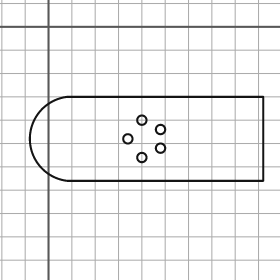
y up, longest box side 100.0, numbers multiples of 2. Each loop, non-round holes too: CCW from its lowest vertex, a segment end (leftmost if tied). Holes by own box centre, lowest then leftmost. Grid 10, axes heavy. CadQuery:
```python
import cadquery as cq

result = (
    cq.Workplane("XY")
    .moveTo(8.0, -66.0)
    .lineTo(92.0, -66.0)
    .lineTo(92.0, -30.0)
    .lineTo(8.0, -30.0)
    .threePointArc((-8.0, -48.0), (8.0, -66.0))
    .close()
    .moveTo(40.0, -56.0)
    .circle(2.0)
    .moveTo(48.0, -52.0)
    .circle(2.0)
    .moveTo(34.0, -48.0)
    .circle(2.0)
    .moveTo(48.0, -44.0)
    .circle(2.0)
    .moveTo(40.0, -40.0)
    .circle(2.0)
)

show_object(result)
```